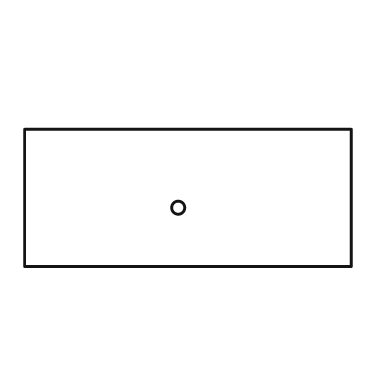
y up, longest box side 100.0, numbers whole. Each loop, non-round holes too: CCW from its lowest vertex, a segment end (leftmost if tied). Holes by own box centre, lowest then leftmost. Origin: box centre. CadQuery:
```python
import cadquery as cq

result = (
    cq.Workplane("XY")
    .moveTo(-50.0, -21.0)
    .lineTo(50.0, -21.0)
    .lineTo(50.0, 21.0)
    .lineTo(-50.0, 21.0)
    .close()
    .moveTo(-3.0, -3.0)
    .circle(2.0)
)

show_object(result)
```